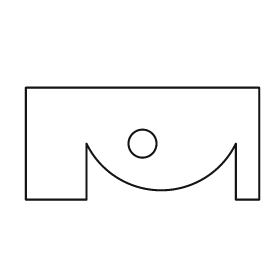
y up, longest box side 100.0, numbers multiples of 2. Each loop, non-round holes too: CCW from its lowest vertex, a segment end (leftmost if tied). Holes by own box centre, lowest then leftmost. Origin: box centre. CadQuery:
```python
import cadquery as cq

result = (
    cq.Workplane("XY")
    .moveTo(-50.0, -24.0)
    .lineTo(-24.0, -24.0)
    .lineTo(-24.0, 0.0)
    .threePointArc((8.0, -20.0), (40.0, 0.0))
    .lineTo(40.0, -24.0)
    .lineTo(50.0, -24.0)
    .lineTo(50.0, 24.0)
    .lineTo(-50.0, 24.0)
    .close()
    .moveTo(0.0, 0.0)
    .circle(6.0)
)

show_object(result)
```